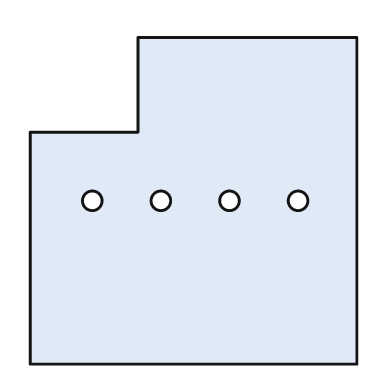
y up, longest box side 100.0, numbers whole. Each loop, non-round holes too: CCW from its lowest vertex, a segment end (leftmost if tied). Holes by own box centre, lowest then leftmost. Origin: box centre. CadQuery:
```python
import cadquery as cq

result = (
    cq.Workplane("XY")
    .moveTo(-50.0, -50.0)
    .lineTo(50.0, -50.0)
    .lineTo(50.0, 50.0)
    .lineTo(-17.0, 50.0)
    .lineTo(-17.0, 21.0)
    .lineTo(-50.0, 21.0)
    .close()
    .moveTo(-31.0, 0.0)
    .circle(3.0)
    .moveTo(-10.0, 0.0)
    .circle(3.0)
    .moveTo(11.0, 0.0)
    .circle(3.0)
    .moveTo(32.0, 0.0)
    .circle(3.0)
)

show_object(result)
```